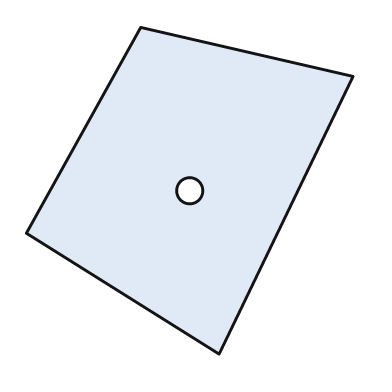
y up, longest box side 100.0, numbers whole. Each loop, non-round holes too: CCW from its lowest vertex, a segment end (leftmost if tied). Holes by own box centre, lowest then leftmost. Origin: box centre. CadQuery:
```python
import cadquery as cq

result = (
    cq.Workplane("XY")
    .moveTo(9.0, -50.0)
    .lineTo(50.0, 35.0)
    .lineTo(-15.0, 50.0)
    .lineTo(-50.0, -13.0)
    .close()
    .moveTo(0.0, 0.0)
    .circle(4.0)
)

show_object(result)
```